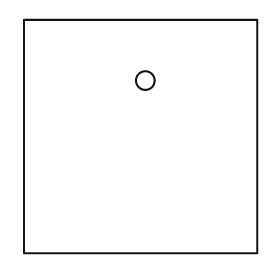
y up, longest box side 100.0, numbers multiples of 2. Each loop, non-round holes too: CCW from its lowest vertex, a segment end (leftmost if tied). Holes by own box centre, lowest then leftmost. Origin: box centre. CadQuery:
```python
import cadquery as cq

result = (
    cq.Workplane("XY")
    .moveTo(-50.0, -50.0)
    .lineTo(50.0, -50.0)
    .lineTo(50.0, 50.0)
    .lineTo(-50.0, 50.0)
    .close()
    .moveTo(2.0, 24.0)
    .circle(4.0)
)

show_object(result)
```